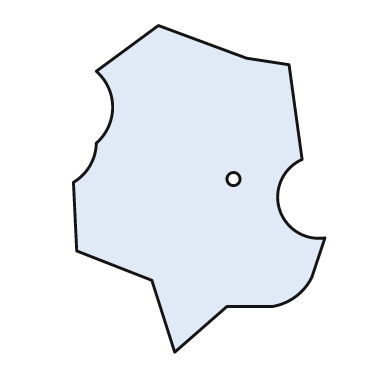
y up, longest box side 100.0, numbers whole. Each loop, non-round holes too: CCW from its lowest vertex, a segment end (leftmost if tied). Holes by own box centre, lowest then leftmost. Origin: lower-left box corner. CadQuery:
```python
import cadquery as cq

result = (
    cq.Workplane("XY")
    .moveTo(31.0, 0.0)
    .lineTo(47.0, 14.0)
    .lineTo(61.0, 14.0)
    .threePointArc((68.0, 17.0), (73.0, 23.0))
    .lineTo(77.0, 35.0)
    .threePointArc((63.0, 44.0), (70.0, 59.0))
    .lineTo(66.0, 88.0)
    .lineTo(53.0, 90.0)
    .lineTo(26.0, 100.0)
    .lineTo(7.0, 86.0)
    .threePointArc((12.0, 75.0), (7.0, 64.0))
    .threePointArc((5.0, 57.0), (0.0, 52.0))
    .lineTo(1.0, 31.0)
    .lineTo(24.0, 22.0)
    .close()
    .moveTo(49.0, 53.0)
    .circle(2.0)
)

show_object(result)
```